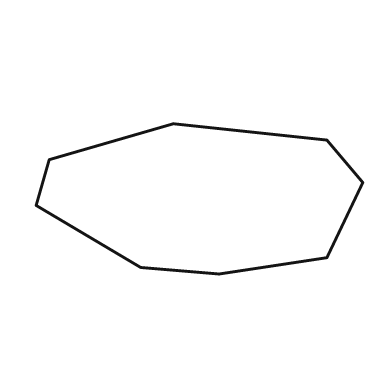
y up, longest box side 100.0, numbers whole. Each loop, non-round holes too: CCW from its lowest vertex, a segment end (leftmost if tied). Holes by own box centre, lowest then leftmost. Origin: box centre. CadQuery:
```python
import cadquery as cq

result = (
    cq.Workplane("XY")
    .moveTo(6.0, -23.0)
    .lineTo(39.0, -18.0)
    .lineTo(50.0, 5.0)
    .lineTo(39.0, 18.0)
    .lineTo(-8.0, 23.0)
    .lineTo(-46.0, 12.0)
    .lineTo(-50.0, -2.0)
    .lineTo(-18.0, -21.0)
    .close()
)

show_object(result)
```